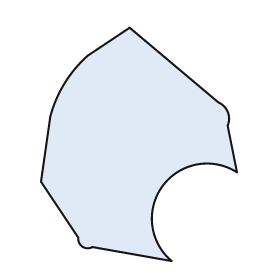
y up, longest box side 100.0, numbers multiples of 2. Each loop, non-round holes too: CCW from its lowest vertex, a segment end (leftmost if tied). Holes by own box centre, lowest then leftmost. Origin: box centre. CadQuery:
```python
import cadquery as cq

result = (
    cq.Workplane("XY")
    .moveTo(14.0, -50.0)
    .threePointArc((10.0, -18.0), (42.0, -12.0))
    .lineTo(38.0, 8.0)
    .threePointArc((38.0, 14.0), (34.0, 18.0))
    .lineTo(-4.0, 50.0)
    .lineTo(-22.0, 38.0)
    .threePointArc((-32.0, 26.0), (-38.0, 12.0))
    .lineTo(-42.0, -16.0)
    .lineTo(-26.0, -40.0)
    .threePointArc((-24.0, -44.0), (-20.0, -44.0))
    .close()
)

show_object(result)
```